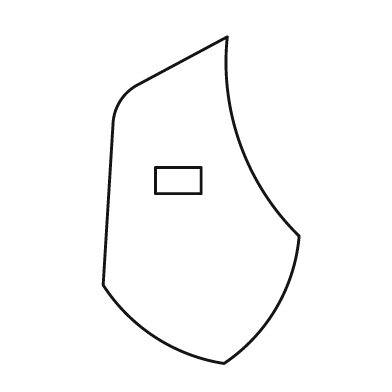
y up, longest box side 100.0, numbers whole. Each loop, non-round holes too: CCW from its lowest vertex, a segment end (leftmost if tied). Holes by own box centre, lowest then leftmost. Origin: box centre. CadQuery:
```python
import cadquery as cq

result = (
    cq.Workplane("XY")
    .moveTo(7.0, -50.0)
    .threePointArc((23.0, -33.0), (30.0, -11.0))
    .threePointArc((12.0, 17.0), (8.0, 50.0))
    .lineTo(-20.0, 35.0)
    .threePointArc((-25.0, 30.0), (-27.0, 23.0))
    .lineTo(-30.0, -26.0)
    .threePointArc((-14.0, -42.0), (7.0, -50.0))
    .close()
    .moveTo(-14.0, 2.0)
    .lineTo(0.0, 2.0)
    .lineTo(0.0, 10.0)
    .lineTo(-14.0, 10.0)
    .close()
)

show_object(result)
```